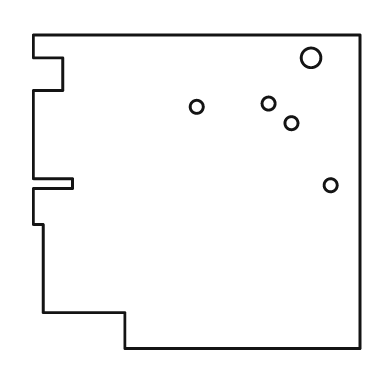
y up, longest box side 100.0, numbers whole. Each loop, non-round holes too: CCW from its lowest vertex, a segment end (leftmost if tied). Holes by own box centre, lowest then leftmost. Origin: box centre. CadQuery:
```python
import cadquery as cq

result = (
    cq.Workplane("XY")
    .moveTo(-22.0, -48.0)
    .lineTo(50.0, -48.0)
    .lineTo(50.0, 48.0)
    .lineTo(-50.0, 48.0)
    .lineTo(-50.0, 41.0)
    .lineTo(-41.0, 41.0)
    .lineTo(-41.0, 31.0)
    .lineTo(-50.0, 31.0)
    .lineTo(-50.0, 4.0)
    .lineTo(-38.0, 4.0)
    .lineTo(-38.0, 1.0)
    .lineTo(-50.0, 1.0)
    .lineTo(-50.0, -10.0)
    .lineTo(-47.0, -10.0)
    .lineTo(-47.0, -37.0)
    .lineTo(-22.0, -37.0)
    .close()
    .moveTo(41.0, 2.0)
    .circle(2.0)
    .moveTo(29.0, 21.0)
    .circle(2.0)
    .moveTo(0.0, 26.0)
    .circle(2.0)
    .moveTo(22.0, 27.0)
    .circle(2.0)
    .moveTo(35.0, 41.0)
    .circle(3.0)
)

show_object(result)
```